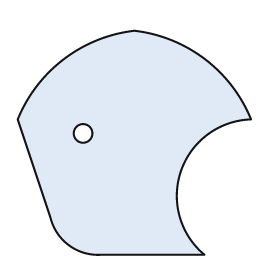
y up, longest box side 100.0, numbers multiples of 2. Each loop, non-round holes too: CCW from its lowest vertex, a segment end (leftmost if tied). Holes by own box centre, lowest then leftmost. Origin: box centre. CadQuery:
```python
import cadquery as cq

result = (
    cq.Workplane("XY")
    .moveTo(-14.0, -48.0)
    .lineTo(30.0, -48.0)
    .threePointArc((20.0, -12.0), (50.0, 10.0))
    .threePointArc((30.0, 36.0), (0.0, 48.0))
    .threePointArc((-30.0, 36.0), (-50.0, 10.0))
    .lineTo(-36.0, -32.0)
    .threePointArc((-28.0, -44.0), (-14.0, -48.0))
    .close()
    .moveTo(-22.0, 4.0)
    .circle(4.0)
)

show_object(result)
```